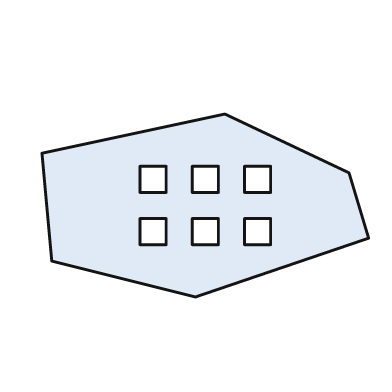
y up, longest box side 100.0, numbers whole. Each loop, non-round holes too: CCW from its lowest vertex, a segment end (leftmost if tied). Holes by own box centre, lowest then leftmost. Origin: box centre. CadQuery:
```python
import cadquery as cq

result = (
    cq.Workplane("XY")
    .moveTo(-3.0, -28.0)
    .lineTo(50.0, -10.0)
    .lineTo(44.0, 10.0)
    .lineTo(6.0, 28.0)
    .lineTo(-50.0, 16.0)
    .lineTo(-47.0, -17.0)
    .close()
    .moveTo(-20.0, -12.0)
    .lineTo(-12.0, -12.0)
    .lineTo(-12.0, -4.0)
    .lineTo(-20.0, -4.0)
    .close()
    .moveTo(-4.0, -12.0)
    .lineTo(4.0, -12.0)
    .lineTo(4.0, -4.0)
    .lineTo(-4.0, -4.0)
    .close()
    .moveTo(12.0, -12.0)
    .lineTo(20.0, -12.0)
    .lineTo(20.0, -4.0)
    .lineTo(12.0, -4.0)
    .close()
    .moveTo(-20.0, 4.0)
    .lineTo(-12.0, 4.0)
    .lineTo(-12.0, 12.0)
    .lineTo(-20.0, 12.0)
    .close()
    .moveTo(-4.0, 4.0)
    .lineTo(4.0, 4.0)
    .lineTo(4.0, 12.0)
    .lineTo(-4.0, 12.0)
    .close()
    .moveTo(12.0, 4.0)
    .lineTo(20.0, 4.0)
    .lineTo(20.0, 12.0)
    .lineTo(12.0, 12.0)
    .close()
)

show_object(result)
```